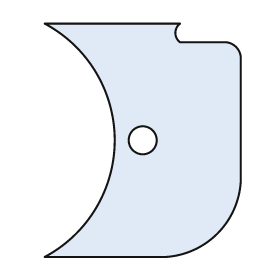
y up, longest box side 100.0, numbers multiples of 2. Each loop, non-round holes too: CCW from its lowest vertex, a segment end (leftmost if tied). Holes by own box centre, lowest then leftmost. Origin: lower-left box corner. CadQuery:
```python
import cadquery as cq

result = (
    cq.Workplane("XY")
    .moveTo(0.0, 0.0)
    .lineTo(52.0, 0.0)
    .threePointArc((74.0, 10.0), (84.0, 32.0))
    .lineTo(84.0, 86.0)
    .threePointArc((82.0, 90.0), (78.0, 92.0))
    .lineTo(58.0, 92.0)
    .threePointArc((56.0, 96.0), (58.0, 100.0))
    .lineTo(0.0, 100.0)
    .threePointArc((30.0, 50.0), (0.0, 0.0))
    .close()
    .moveTo(42.0, 50.0)
    .circle(6.0)
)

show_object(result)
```